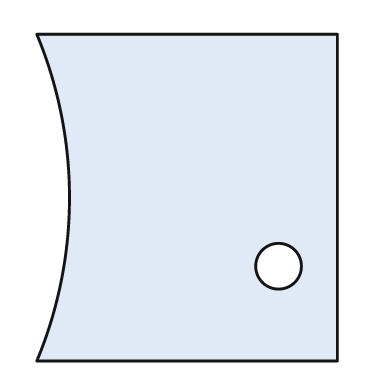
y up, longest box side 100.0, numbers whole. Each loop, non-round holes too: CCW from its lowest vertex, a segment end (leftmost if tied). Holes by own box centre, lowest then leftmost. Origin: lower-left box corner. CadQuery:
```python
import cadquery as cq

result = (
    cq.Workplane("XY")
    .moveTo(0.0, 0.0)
    .lineTo(92.0, 0.0)
    .lineTo(92.0, 100.0)
    .lineTo(0.0, 100.0)
    .threePointArc((10.0, 50.0), (0.0, 0.0))
    .close()
    .moveTo(74.0, 29.0)
    .circle(7.0)
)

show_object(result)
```